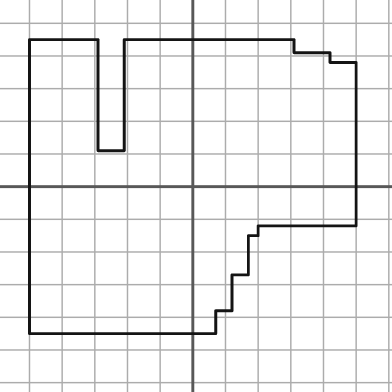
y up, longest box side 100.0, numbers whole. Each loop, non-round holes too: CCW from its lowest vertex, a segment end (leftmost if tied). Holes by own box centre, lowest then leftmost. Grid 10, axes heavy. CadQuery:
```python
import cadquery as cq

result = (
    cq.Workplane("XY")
    .moveTo(-50.0, -45.0)
    .lineTo(7.0, -45.0)
    .lineTo(7.0, -38.0)
    .lineTo(12.0, -38.0)
    .lineTo(12.0, -27.0)
    .lineTo(17.0, -27.0)
    .lineTo(17.0, -15.0)
    .lineTo(20.0, -15.0)
    .lineTo(20.0, -12.0)
    .lineTo(50.0, -12.0)
    .lineTo(50.0, 38.0)
    .lineTo(42.0, 38.0)
    .lineTo(42.0, 41.0)
    .lineTo(31.0, 41.0)
    .lineTo(31.0, 45.0)
    .lineTo(-21.0, 45.0)
    .lineTo(-21.0, 11.0)
    .lineTo(-29.0, 11.0)
    .lineTo(-29.0, 45.0)
    .lineTo(-50.0, 45.0)
    .close()
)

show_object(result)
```